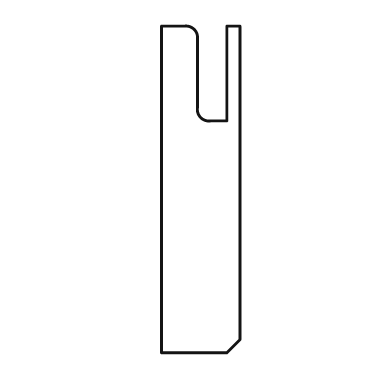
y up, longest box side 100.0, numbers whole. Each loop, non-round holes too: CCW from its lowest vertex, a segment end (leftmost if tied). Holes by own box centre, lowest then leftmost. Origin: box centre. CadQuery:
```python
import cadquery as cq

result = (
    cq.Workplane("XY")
    .moveTo(-12.0, -50.0)
    .lineTo(8.0, -50.0)
    .lineTo(12.0, -46.0)
    .lineTo(12.0, 50.0)
    .lineTo(8.0, 50.0)
    .lineTo(8.0, 21.0)
    .lineTo(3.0, 21.0)
    .threePointArc((0.0, 22.0), (-1.0, 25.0))
    .lineTo(-1.0, 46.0)
    .threePointArc((-2.0, 49.0), (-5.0, 50.0))
    .lineTo(-12.0, 50.0)
    .close()
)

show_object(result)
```